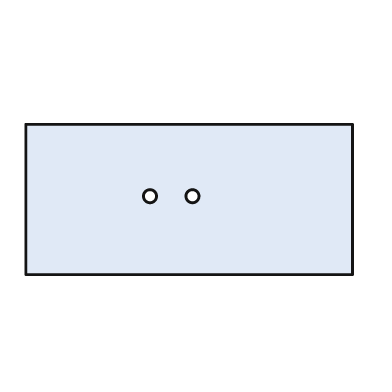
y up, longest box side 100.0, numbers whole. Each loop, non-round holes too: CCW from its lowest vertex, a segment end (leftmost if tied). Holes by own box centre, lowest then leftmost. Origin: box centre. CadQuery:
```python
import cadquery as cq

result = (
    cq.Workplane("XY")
    .moveTo(-50.0, -23.0)
    .lineTo(50.0, -23.0)
    .lineTo(50.0, 23.0)
    .lineTo(-50.0, 23.0)
    .close()
    .moveTo(-12.0, 1.0)
    .circle(2.0)
    .moveTo(1.0, 1.0)
    .circle(2.0)
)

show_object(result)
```